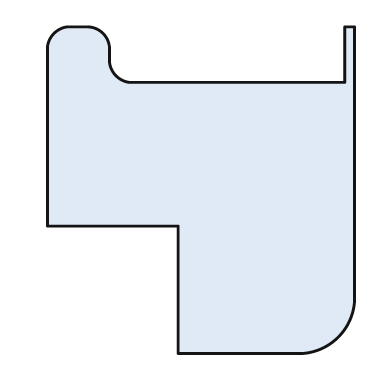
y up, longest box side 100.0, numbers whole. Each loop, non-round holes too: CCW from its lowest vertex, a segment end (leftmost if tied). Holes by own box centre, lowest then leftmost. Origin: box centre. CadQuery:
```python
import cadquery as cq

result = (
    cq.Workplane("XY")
    .moveTo(-7.0, -50.0)
    .lineTo(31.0, -50.0)
    .threePointArc((42.0, -45.0), (47.0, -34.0))
    .lineTo(47.0, 50.0)
    .lineTo(44.0, 50.0)
    .lineTo(44.0, 33.0)
    .lineTo(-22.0, 33.0)
    .threePointArc((-26.0, 35.0), (-28.0, 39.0))
    .lineTo(-28.0, 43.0)
    .threePointArc((-30.0, 48.0), (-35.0, 50.0))
    .lineTo(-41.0, 50.0)
    .threePointArc((-45.0, 48.0), (-47.0, 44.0))
    .lineTo(-47.0, -11.0)
    .lineTo(-7.0, -11.0)
    .close()
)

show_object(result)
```